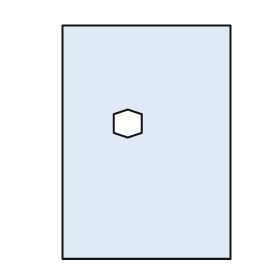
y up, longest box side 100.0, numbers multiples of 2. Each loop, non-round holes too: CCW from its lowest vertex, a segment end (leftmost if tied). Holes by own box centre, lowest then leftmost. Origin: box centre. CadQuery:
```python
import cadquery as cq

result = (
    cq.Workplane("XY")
    .moveTo(-36.0, -50.0)
    .lineTo(36.0, -50.0)
    .lineTo(36.0, 50.0)
    .lineTo(-36.0, 50.0)
    .close()
    .moveTo(-8.0, 2.0)
    .lineTo(-2.0, 4.0)
    .lineTo(-2.0, 12.0)
    .lineTo(-8.0, 14.0)
    .lineTo(-14.0, 12.0)
    .lineTo(-14.0, 4.0)
    .close()
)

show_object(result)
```